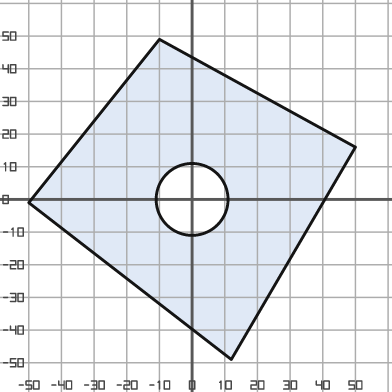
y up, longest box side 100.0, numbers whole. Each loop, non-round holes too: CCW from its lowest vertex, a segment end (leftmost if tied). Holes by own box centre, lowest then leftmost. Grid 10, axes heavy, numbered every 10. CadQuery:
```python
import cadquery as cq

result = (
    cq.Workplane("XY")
    .moveTo(12.0, -49.0)
    .lineTo(50.0, 16.0)
    .lineTo(-10.0, 49.0)
    .lineTo(-50.0, -1.0)
    .close()
    .moveTo(0.0, 0.0)
    .circle(11.0)
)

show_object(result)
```